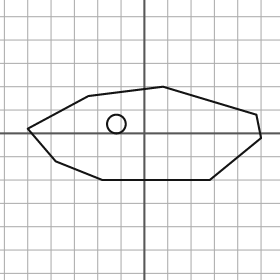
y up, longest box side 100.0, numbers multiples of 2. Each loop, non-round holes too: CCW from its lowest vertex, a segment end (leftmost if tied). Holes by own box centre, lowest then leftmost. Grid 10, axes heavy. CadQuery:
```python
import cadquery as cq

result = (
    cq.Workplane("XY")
    .moveTo(-18.0, -20.0)
    .lineTo(28.0, -20.0)
    .lineTo(50.0, -2.0)
    .lineTo(48.0, 8.0)
    .lineTo(8.0, 20.0)
    .lineTo(-24.0, 16.0)
    .lineTo(-50.0, 2.0)
    .lineTo(-38.0, -12.0)
    .close()
    .moveTo(-12.0, 4.0)
    .circle(4.0)
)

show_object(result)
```